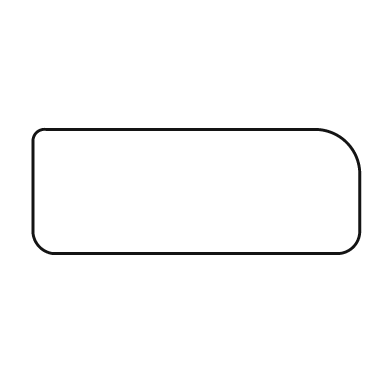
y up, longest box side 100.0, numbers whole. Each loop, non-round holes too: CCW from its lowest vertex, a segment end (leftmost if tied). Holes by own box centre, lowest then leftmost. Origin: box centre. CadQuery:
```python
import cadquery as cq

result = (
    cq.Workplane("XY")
    .moveTo(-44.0, -19.0)
    .lineTo(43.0, -19.0)
    .threePointArc((48.0, -17.0), (50.0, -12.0))
    .lineTo(50.0, 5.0)
    .threePointArc((46.0, 15.0), (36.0, 19.0))
    .lineTo(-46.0, 19.0)
    .threePointArc((-49.0, 18.0), (-50.0, 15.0))
    .lineTo(-50.0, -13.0)
    .threePointArc((-48.0, -17.0), (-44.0, -19.0))
    .close()
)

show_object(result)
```